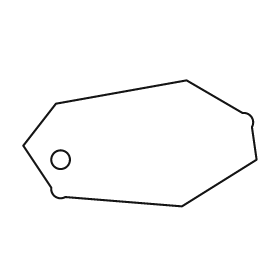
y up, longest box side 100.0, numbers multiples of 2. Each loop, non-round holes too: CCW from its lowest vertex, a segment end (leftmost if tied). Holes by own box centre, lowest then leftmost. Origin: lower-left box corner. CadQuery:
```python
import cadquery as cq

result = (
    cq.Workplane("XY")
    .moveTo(68.0, 0.0)
    .lineTo(100.0, 20.0)
    .lineTo(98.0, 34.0)
    .threePointArc((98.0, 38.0), (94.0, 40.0))
    .lineTo(70.0, 54.0)
    .lineTo(14.0, 44.0)
    .lineTo(0.0, 26.0)
    .lineTo(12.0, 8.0)
    .threePointArc((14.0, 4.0), (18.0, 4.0))
    .close()
    .moveTo(16.0, 20.0)
    .circle(4.0)
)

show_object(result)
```